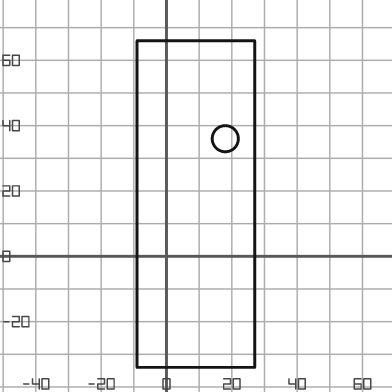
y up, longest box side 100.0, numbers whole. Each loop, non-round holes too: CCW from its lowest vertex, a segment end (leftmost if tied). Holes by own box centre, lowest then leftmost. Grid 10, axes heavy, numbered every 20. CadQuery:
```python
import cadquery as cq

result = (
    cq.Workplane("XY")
    .moveTo(-9.0, -34.0)
    .lineTo(27.0, -34.0)
    .lineTo(27.0, 66.0)
    .lineTo(-9.0, 66.0)
    .close()
    .moveTo(18.0, 36.0)
    .circle(4.0)
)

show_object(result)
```